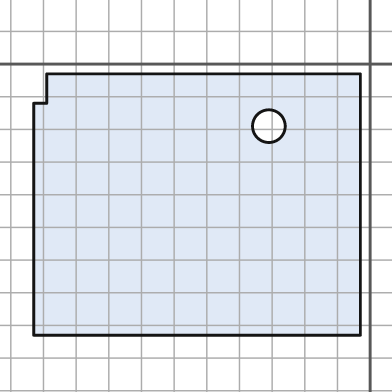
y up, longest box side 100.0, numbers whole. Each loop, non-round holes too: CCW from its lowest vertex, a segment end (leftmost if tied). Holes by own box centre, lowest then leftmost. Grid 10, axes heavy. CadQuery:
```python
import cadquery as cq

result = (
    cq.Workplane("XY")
    .moveTo(-103.0, -83.0)
    .lineTo(-3.0, -83.0)
    .lineTo(-3.0, -3.0)
    .lineTo(-99.0, -3.0)
    .lineTo(-99.0, -12.0)
    .lineTo(-103.0, -12.0)
    .close()
    .moveTo(-31.0, -19.0)
    .circle(5.0)
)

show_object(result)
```